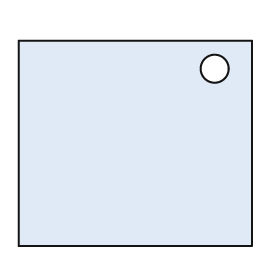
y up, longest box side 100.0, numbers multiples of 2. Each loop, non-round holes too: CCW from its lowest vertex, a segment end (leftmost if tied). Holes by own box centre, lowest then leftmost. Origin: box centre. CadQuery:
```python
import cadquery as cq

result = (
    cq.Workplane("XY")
    .moveTo(-50.0, -44.0)
    .lineTo(50.0, -44.0)
    .lineTo(50.0, 44.0)
    .lineTo(-50.0, 44.0)
    .close()
    .moveTo(34.0, 32.0)
    .circle(6.0)
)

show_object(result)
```